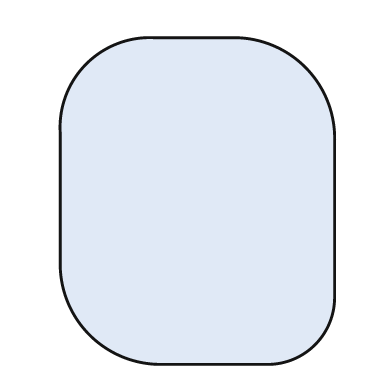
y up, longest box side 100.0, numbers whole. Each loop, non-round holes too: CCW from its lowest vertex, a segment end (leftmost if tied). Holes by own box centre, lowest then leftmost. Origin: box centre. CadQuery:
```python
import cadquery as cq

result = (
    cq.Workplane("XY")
    .moveTo(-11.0, -50.0)
    .lineTo(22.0, -50.0)
    .threePointArc((36.0, -44.0), (42.0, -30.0))
    .lineTo(42.0, 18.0)
    .threePointArc((33.0, 41.0), (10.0, 50.0))
    .lineTo(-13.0, 50.0)
    .threePointArc((-34.0, 42.0), (-42.0, 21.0))
    .lineTo(-42.0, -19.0)
    .threePointArc((-33.0, -41.0), (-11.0, -50.0))
    .close()
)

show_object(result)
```